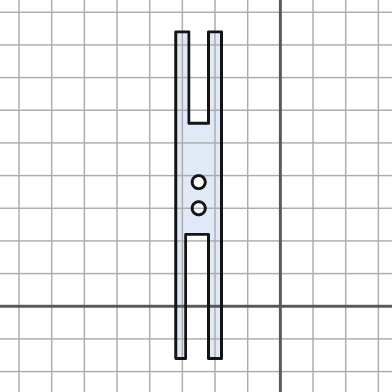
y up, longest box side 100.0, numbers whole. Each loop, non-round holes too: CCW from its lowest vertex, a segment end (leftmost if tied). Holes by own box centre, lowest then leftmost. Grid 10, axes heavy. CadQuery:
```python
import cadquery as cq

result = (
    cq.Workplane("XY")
    .moveTo(-32.0, -16.0)
    .lineTo(-29.0, -16.0)
    .lineTo(-29.0, 22.0)
    .lineTo(-22.0, 22.0)
    .lineTo(-22.0, -16.0)
    .lineTo(-18.0, -16.0)
    .lineTo(-18.0, 84.0)
    .lineTo(-22.0, 84.0)
    .lineTo(-22.0, 56.0)
    .lineTo(-28.0, 56.0)
    .lineTo(-28.0, 84.0)
    .lineTo(-32.0, 84.0)
    .close()
    .moveTo(-25.0, 30.0)
    .circle(2.0)
    .moveTo(-25.0, 38.0)
    .circle(2.0)
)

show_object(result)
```